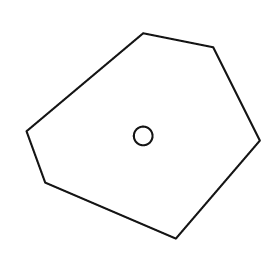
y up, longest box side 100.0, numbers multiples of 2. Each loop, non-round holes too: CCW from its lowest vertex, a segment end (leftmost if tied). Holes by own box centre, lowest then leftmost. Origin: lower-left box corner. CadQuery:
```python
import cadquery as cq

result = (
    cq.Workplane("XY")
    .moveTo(64.0, 0.0)
    .lineTo(100.0, 42.0)
    .lineTo(80.0, 82.0)
    .lineTo(50.0, 88.0)
    .lineTo(0.0, 46.0)
    .lineTo(8.0, 24.0)
    .close()
    .moveTo(50.0, 44.0)
    .circle(4.0)
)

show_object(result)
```